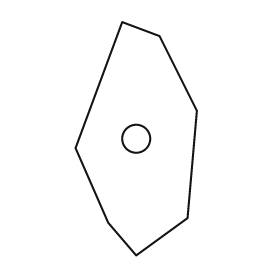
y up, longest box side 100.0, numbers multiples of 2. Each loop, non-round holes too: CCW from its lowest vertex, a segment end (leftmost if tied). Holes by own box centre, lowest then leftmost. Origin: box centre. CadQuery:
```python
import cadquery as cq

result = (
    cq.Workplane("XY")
    .moveTo(0.0, -50.0)
    .lineTo(22.0, -34.0)
    .lineTo(26.0, 12.0)
    .lineTo(10.0, 44.0)
    .lineTo(-6.0, 50.0)
    .lineTo(-26.0, -4.0)
    .lineTo(-12.0, -36.0)
    .close()
    .moveTo(0.0, 0.0)
    .circle(6.0)
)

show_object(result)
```